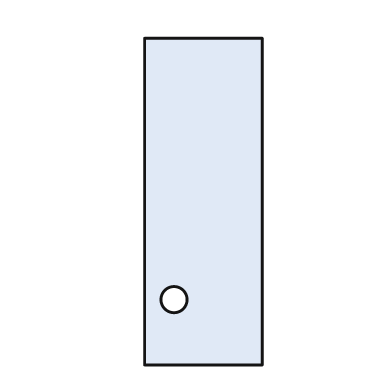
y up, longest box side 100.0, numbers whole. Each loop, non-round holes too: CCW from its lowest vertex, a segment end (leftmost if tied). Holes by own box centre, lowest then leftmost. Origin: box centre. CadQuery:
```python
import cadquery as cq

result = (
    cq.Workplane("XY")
    .moveTo(-18.0, -50.0)
    .lineTo(18.0, -50.0)
    .lineTo(18.0, 50.0)
    .lineTo(-18.0, 50.0)
    .close()
    .moveTo(-9.0, -30.0)
    .circle(4.0)
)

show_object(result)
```